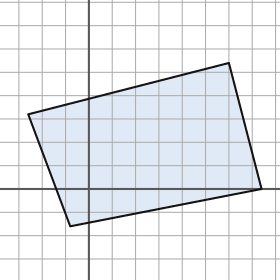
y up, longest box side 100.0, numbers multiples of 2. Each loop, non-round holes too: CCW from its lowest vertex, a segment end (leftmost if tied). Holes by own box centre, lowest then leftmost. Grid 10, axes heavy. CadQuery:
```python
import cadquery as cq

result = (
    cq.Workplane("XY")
    .moveTo(-8.0, -16.0)
    .lineTo(74.0, 0.0)
    .lineTo(60.0, 54.0)
    .lineTo(-26.0, 32.0)
    .close()
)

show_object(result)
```